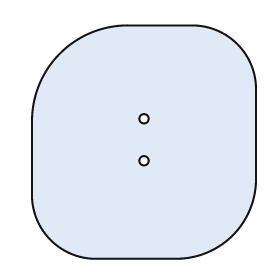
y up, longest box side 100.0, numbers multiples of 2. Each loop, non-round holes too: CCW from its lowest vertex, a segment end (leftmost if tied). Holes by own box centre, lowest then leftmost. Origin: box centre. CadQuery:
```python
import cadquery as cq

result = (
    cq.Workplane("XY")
    .moveTo(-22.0, -50.0)
    .lineTo(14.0, -50.0)
    .threePointArc((38.0, -40.0), (48.0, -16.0))
    .lineTo(48.0, 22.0)
    .threePointArc((40.0, 42.0), (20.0, 50.0))
    .lineTo(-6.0, 50.0)
    .threePointArc((-36.0, 38.0), (-48.0, 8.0))
    .lineTo(-48.0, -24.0)
    .threePointArc((-40.0, -42.0), (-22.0, -50.0))
    .close()
    .moveTo(0.0, -8.0)
    .circle(2.0)
    .moveTo(0.0, 10.0)
    .circle(2.0)
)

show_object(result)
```